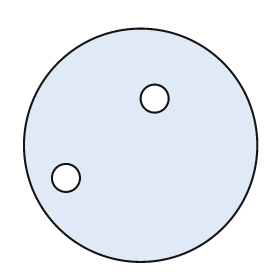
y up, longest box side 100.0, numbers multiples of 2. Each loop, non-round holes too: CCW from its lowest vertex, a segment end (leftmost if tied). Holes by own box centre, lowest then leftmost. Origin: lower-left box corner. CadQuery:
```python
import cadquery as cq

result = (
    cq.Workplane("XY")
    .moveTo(50.0, 50.0)
    .circle(50.0)
    .moveTo(18.0, 36.0)
    .circle(6.0)
    .moveTo(56.0, 70.0)
    .circle(6.0)
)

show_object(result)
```